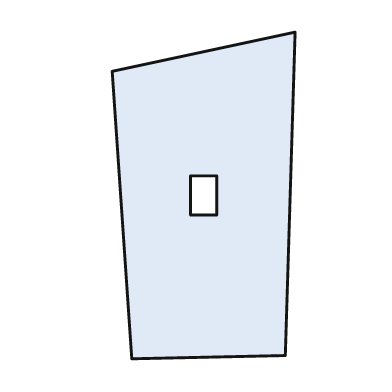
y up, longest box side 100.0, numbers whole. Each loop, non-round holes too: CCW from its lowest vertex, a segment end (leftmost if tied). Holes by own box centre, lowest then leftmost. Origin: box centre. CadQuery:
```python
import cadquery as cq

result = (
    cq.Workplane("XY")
    .moveTo(-22.0, -50.0)
    .lineTo(25.0, -49.0)
    .lineTo(28.0, 50.0)
    .lineTo(-28.0, 38.0)
    .close()
    .moveTo(-4.0, -6.0)
    .lineTo(4.0, -6.0)
    .lineTo(4.0, 6.0)
    .lineTo(-4.0, 6.0)
    .close()
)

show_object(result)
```